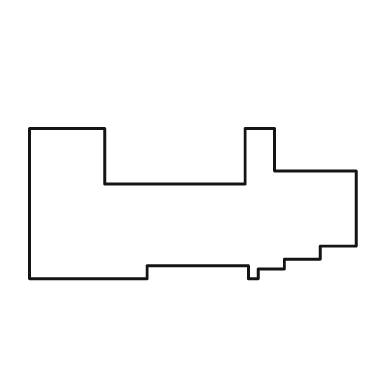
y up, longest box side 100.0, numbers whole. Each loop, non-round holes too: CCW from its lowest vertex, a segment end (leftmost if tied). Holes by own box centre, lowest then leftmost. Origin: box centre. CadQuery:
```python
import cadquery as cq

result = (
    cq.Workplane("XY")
    .moveTo(-50.0, -23.0)
    .lineTo(-14.0, -23.0)
    .lineTo(-14.0, -19.0)
    .lineTo(17.0, -19.0)
    .lineTo(17.0, -23.0)
    .lineTo(20.0, -23.0)
    .lineTo(20.0, -20.0)
    .lineTo(28.0, -20.0)
    .lineTo(28.0, -17.0)
    .lineTo(39.0, -17.0)
    .lineTo(39.0, -13.0)
    .lineTo(50.0, -13.0)
    .lineTo(50.0, 10.0)
    .lineTo(25.0, 10.0)
    .lineTo(25.0, 23.0)
    .lineTo(16.0, 23.0)
    .lineTo(16.0, 6.0)
    .lineTo(-27.0, 6.0)
    .lineTo(-27.0, 23.0)
    .lineTo(-50.0, 23.0)
    .close()
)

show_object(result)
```